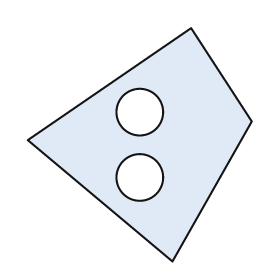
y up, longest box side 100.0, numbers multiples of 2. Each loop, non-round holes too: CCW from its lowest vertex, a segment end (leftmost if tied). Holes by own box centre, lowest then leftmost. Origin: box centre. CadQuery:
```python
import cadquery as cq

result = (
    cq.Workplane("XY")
    .moveTo(14.0, -50.0)
    .lineTo(48.0, 10.0)
    .lineTo(22.0, 50.0)
    .lineTo(-48.0, 2.0)
    .close()
    .moveTo(0.0, -14.0)
    .circle(10.0)
    .moveTo(0.0, 14.0)
    .circle(10.0)
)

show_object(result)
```